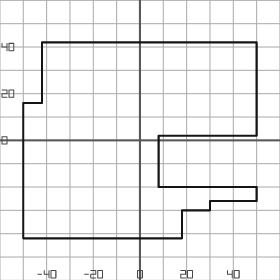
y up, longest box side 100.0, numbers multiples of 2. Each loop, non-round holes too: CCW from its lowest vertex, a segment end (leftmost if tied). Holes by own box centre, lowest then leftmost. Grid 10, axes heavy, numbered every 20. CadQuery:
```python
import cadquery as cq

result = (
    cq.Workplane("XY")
    .moveTo(-50.0, -42.0)
    .lineTo(18.0, -42.0)
    .lineTo(18.0, -30.0)
    .lineTo(30.0, -30.0)
    .lineTo(30.0, -26.0)
    .lineTo(50.0, -26.0)
    .lineTo(50.0, -20.0)
    .lineTo(8.0, -20.0)
    .lineTo(8.0, 2.0)
    .lineTo(50.0, 2.0)
    .lineTo(50.0, 42.0)
    .lineTo(-42.0, 42.0)
    .lineTo(-42.0, 16.0)
    .lineTo(-50.0, 16.0)
    .close()
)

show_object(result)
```